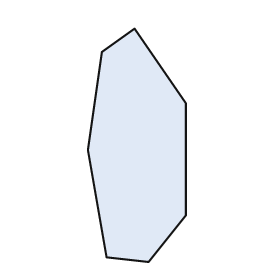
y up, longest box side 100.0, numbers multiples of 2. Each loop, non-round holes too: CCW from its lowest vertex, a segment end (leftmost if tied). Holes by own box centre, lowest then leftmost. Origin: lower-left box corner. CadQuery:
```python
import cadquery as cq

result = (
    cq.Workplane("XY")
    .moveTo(26.0, 0.0)
    .lineTo(42.0, 20.0)
    .lineTo(42.0, 68.0)
    .lineTo(20.0, 100.0)
    .lineTo(6.0, 90.0)
    .lineTo(0.0, 48.0)
    .lineTo(8.0, 2.0)
    .close()
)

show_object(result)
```